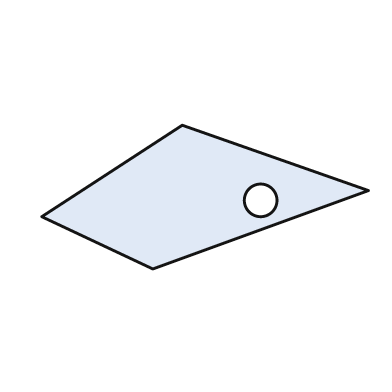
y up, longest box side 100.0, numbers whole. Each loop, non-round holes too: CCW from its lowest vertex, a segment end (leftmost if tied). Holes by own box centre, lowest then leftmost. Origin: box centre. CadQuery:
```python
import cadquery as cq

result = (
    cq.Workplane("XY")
    .moveTo(-16.0, -22.0)
    .lineTo(50.0, 2.0)
    .lineTo(-7.0, 22.0)
    .lineTo(-50.0, -6.0)
    .close()
    .moveTo(17.0, -1.0)
    .circle(5.0)
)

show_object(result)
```